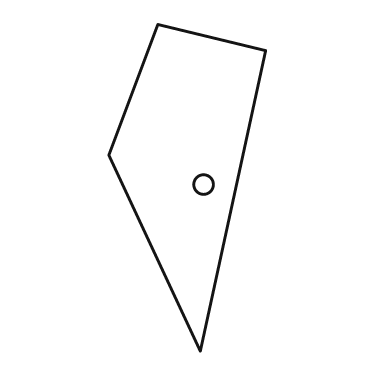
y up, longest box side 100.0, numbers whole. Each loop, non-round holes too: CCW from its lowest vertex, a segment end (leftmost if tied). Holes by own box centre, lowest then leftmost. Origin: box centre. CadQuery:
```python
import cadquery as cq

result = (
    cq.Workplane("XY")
    .moveTo(4.0, -50.0)
    .lineTo(24.0, 42.0)
    .lineTo(-9.0, 50.0)
    .lineTo(-24.0, 10.0)
    .close()
    .moveTo(5.0, 1.0)
    .circle(3.0)
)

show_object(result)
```